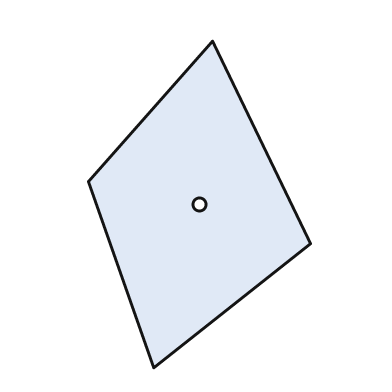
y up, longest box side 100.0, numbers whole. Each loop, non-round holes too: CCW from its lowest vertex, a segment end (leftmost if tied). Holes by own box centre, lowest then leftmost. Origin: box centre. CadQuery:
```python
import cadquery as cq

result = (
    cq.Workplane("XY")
    .moveTo(-14.0, -50.0)
    .lineTo(34.0, -12.0)
    .lineTo(4.0, 50.0)
    .lineTo(-34.0, 7.0)
    .close()
    .moveTo(0.0, 0.0)
    .circle(2.0)
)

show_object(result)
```